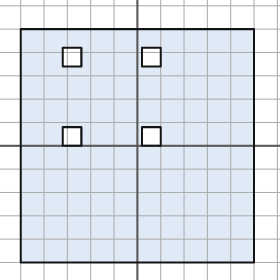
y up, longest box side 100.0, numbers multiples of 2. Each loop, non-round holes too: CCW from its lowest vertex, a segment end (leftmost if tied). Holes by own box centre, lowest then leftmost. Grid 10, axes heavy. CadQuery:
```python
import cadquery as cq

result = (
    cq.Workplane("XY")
    .moveTo(-50.0, -50.0)
    .lineTo(50.0, -50.0)
    .lineTo(50.0, 50.0)
    .lineTo(-50.0, 50.0)
    .close()
    .moveTo(-32.0, 0.0)
    .lineTo(-24.0, 0.0)
    .lineTo(-24.0, 8.0)
    .lineTo(-32.0, 8.0)
    .close()
    .moveTo(2.0, 0.0)
    .lineTo(10.0, 0.0)
    .lineTo(10.0, 8.0)
    .lineTo(2.0, 8.0)
    .close()
    .moveTo(-32.0, 34.0)
    .lineTo(-24.0, 34.0)
    .lineTo(-24.0, 42.0)
    .lineTo(-32.0, 42.0)
    .close()
    .moveTo(2.0, 34.0)
    .lineTo(10.0, 34.0)
    .lineTo(10.0, 42.0)
    .lineTo(2.0, 42.0)
    .close()
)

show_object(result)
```